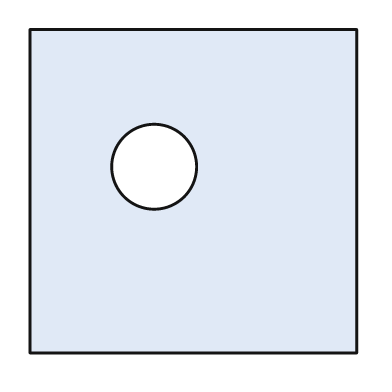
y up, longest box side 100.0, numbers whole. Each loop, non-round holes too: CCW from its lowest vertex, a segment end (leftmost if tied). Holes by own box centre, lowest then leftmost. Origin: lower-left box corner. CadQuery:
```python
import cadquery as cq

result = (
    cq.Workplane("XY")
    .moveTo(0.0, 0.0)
    .lineTo(100.0, 0.0)
    .lineTo(100.0, 99.0)
    .lineTo(0.0, 99.0)
    .close()
    .moveTo(38.0, 57.0)
    .circle(13.0)
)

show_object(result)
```